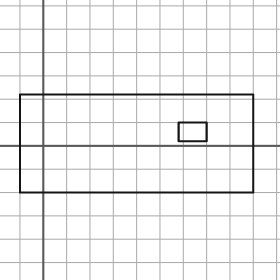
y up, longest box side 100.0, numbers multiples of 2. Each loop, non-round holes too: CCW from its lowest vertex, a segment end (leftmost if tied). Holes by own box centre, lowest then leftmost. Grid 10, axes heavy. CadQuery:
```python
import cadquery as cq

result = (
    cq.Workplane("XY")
    .moveTo(-10.0, -20.0)
    .lineTo(90.0, -20.0)
    .lineTo(90.0, 22.0)
    .lineTo(-10.0, 22.0)
    .close()
    .moveTo(58.0, 2.0)
    .lineTo(70.0, 2.0)
    .lineTo(70.0, 10.0)
    .lineTo(58.0, 10.0)
    .close()
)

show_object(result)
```